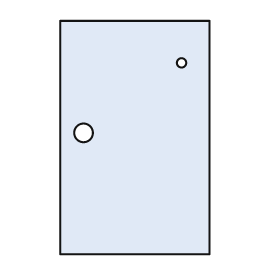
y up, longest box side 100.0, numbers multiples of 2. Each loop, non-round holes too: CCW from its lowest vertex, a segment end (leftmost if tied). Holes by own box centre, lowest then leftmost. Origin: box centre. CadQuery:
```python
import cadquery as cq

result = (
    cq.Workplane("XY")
    .moveTo(-32.0, -50.0)
    .lineTo(32.0, -50.0)
    .lineTo(32.0, 50.0)
    .lineTo(-32.0, 50.0)
    .close()
    .moveTo(-22.0, 2.0)
    .circle(4.0)
    .moveTo(20.0, 32.0)
    .circle(2.0)
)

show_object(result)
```